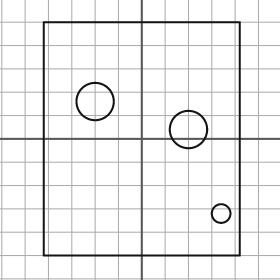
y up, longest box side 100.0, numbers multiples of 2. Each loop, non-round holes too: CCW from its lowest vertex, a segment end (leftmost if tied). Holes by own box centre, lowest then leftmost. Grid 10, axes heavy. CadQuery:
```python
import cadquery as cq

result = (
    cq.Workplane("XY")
    .moveTo(-42.0, -50.0)
    .lineTo(42.0, -50.0)
    .lineTo(42.0, 50.0)
    .lineTo(-42.0, 50.0)
    .close()
    .moveTo(34.0, -32.0)
    .circle(4.0)
    .moveTo(20.0, 4.0)
    .circle(8.0)
    .moveTo(-20.0, 16.0)
    .circle(8.0)
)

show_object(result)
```